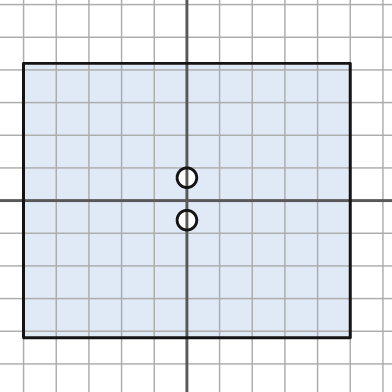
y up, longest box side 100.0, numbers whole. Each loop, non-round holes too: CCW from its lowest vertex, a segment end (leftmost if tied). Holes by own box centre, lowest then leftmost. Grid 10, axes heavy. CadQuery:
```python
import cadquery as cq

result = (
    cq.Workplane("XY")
    .moveTo(-50.0, -42.0)
    .lineTo(50.0, -42.0)
    .lineTo(50.0, 42.0)
    .lineTo(-50.0, 42.0)
    .close()
    .moveTo(0.0, -6.0)
    .circle(3.0)
    .moveTo(0.0, 7.0)
    .circle(3.0)
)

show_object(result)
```